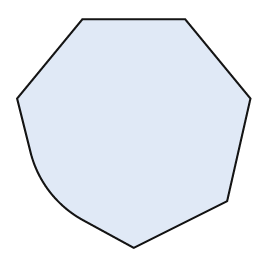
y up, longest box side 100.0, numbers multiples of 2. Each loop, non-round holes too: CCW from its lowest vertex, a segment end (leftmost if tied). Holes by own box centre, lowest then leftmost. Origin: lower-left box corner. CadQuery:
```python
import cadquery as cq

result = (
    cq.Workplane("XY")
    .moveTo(50.0, 0.0)
    .lineTo(90.0, 20.0)
    .lineTo(100.0, 64.0)
    .lineTo(72.0, 98.0)
    .lineTo(28.0, 98.0)
    .lineTo(0.0, 64.0)
    .lineTo(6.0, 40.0)
    .threePointArc((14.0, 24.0), (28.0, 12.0))
    .close()
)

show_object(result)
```